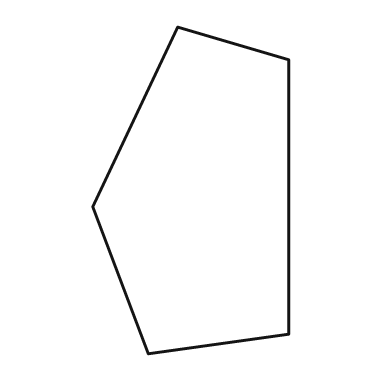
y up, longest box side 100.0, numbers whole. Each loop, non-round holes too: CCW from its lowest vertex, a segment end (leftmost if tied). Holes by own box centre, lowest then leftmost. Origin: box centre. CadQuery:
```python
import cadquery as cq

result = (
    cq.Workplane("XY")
    .moveTo(-13.0, -50.0)
    .lineTo(30.0, -44.0)
    .lineTo(30.0, 40.0)
    .lineTo(-4.0, 50.0)
    .lineTo(-30.0, -5.0)
    .close()
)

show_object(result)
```